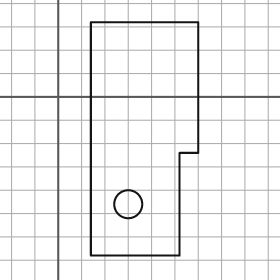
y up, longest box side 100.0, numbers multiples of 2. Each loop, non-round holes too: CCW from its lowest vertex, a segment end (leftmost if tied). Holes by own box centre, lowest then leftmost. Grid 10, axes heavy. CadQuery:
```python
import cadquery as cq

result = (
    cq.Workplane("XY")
    .moveTo(14.0, -68.0)
    .lineTo(52.0, -68.0)
    .lineTo(52.0, -24.0)
    .lineTo(60.0, -24.0)
    .lineTo(60.0, 32.0)
    .lineTo(14.0, 32.0)
    .close()
    .moveTo(30.0, -46.0)
    .circle(6.0)
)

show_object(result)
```